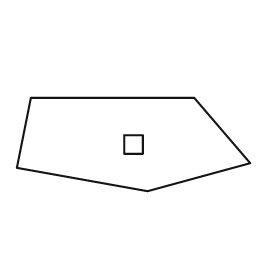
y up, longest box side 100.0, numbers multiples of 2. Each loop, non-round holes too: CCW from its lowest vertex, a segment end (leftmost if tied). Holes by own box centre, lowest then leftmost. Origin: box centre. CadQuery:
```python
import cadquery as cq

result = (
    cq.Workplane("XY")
    .moveTo(6.0, -20.0)
    .lineTo(50.0, -8.0)
    .lineTo(26.0, 20.0)
    .lineTo(-44.0, 20.0)
    .lineTo(-50.0, -10.0)
    .close()
    .moveTo(-4.0, -4.0)
    .lineTo(4.0, -4.0)
    .lineTo(4.0, 4.0)
    .lineTo(-4.0, 4.0)
    .close()
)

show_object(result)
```